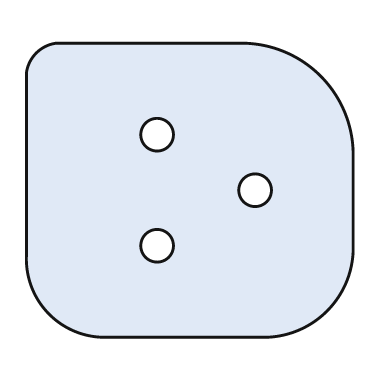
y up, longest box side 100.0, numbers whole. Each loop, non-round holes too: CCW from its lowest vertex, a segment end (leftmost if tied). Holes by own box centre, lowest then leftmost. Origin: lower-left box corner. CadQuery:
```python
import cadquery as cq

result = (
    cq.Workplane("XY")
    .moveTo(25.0, 0.0)
    .lineTo(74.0, 0.0)
    .threePointArc((92.0, 8.0), (100.0, 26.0))
    .lineTo(100.0, 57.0)
    .threePointArc((90.0, 80.0), (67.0, 90.0))
    .lineTo(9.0, 90.0)
    .threePointArc((3.0, 87.0), (0.0, 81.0))
    .lineTo(0.0, 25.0)
    .threePointArc((7.0, 7.0), (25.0, 0.0))
    .close()
    .moveTo(40.0, 28.0)
    .circle(5.0)
    .moveTo(70.0, 45.0)
    .circle(5.0)
    .moveTo(40.0, 62.0)
    .circle(5.0)
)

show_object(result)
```